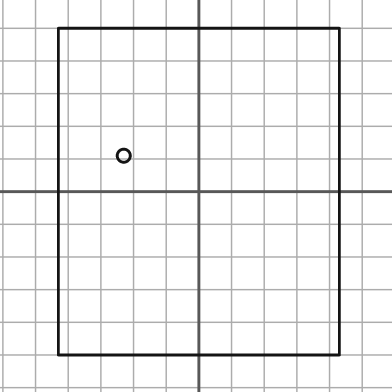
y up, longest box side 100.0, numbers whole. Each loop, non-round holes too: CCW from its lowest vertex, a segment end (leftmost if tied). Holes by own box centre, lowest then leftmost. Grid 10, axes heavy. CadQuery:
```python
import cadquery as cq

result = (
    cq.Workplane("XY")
    .moveTo(-43.0, -50.0)
    .lineTo(43.0, -50.0)
    .lineTo(43.0, 50.0)
    .lineTo(-43.0, 50.0)
    .close()
    .moveTo(-23.0, 11.0)
    .circle(2.0)
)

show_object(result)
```